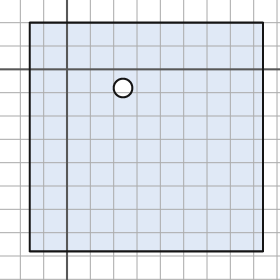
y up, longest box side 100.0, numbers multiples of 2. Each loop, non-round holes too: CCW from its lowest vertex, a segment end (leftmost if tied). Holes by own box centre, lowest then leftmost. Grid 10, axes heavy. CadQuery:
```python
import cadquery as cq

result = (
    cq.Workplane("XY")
    .moveTo(-16.0, -78.0)
    .lineTo(84.0, -78.0)
    .lineTo(84.0, 20.0)
    .lineTo(-16.0, 20.0)
    .close()
    .moveTo(24.0, -8.0)
    .circle(4.0)
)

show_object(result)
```